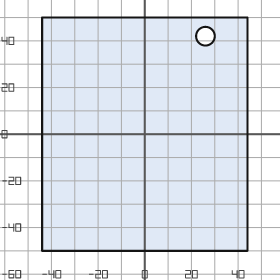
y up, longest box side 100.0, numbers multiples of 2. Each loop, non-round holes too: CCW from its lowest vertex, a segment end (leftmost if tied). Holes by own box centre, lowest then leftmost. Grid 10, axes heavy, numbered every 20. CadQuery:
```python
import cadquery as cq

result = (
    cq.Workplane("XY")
    .moveTo(-44.0, -50.0)
    .lineTo(44.0, -50.0)
    .lineTo(44.0, 50.0)
    .lineTo(-44.0, 50.0)
    .close()
    .moveTo(26.0, 42.0)
    .circle(4.0)
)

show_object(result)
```